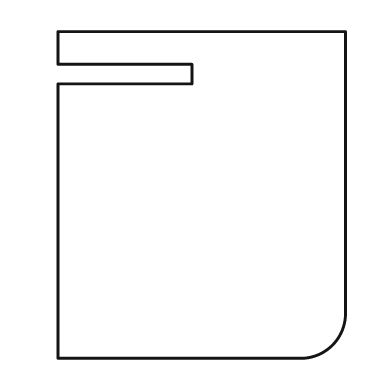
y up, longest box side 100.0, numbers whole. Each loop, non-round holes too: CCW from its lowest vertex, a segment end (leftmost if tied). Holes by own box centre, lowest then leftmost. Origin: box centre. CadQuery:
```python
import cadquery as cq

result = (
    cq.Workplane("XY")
    .moveTo(-44.0, -50.0)
    .lineTo(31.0, -50.0)
    .threePointArc((40.0, -46.0), (44.0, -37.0))
    .lineTo(44.0, 50.0)
    .lineTo(-44.0, 50.0)
    .lineTo(-44.0, 40.0)
    .lineTo(-3.0, 40.0)
    .lineTo(-3.0, 34.0)
    .lineTo(-44.0, 34.0)
    .close()
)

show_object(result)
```